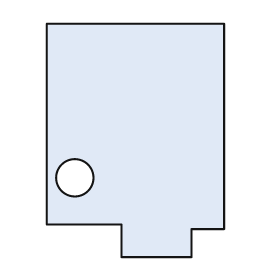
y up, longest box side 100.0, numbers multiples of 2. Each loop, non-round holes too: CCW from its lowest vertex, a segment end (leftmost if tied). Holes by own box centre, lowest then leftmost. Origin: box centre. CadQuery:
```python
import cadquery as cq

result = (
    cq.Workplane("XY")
    .moveTo(-6.0, -50.0)
    .lineTo(24.0, -50.0)
    .lineTo(24.0, -38.0)
    .lineTo(38.0, -38.0)
    .lineTo(38.0, 50.0)
    .lineTo(-38.0, 50.0)
    .lineTo(-38.0, -36.0)
    .lineTo(-6.0, -36.0)
    .close()
    .moveTo(-26.0, -16.0)
    .circle(8.0)
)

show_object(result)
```